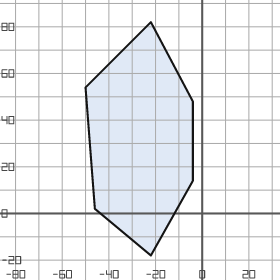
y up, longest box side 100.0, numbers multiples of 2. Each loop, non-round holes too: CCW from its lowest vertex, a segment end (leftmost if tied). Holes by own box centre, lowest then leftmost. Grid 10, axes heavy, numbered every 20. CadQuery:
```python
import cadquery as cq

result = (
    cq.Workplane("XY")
    .moveTo(-22.0, -18.0)
    .lineTo(-4.0, 14.0)
    .lineTo(-4.0, 48.0)
    .lineTo(-22.0, 82.0)
    .lineTo(-50.0, 54.0)
    .lineTo(-46.0, 2.0)
    .close()
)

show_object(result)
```